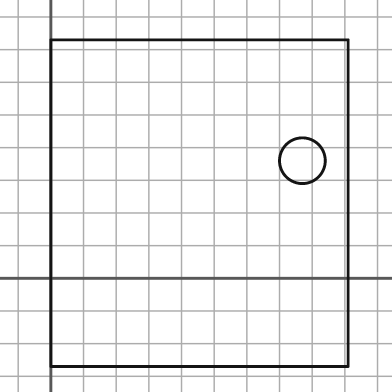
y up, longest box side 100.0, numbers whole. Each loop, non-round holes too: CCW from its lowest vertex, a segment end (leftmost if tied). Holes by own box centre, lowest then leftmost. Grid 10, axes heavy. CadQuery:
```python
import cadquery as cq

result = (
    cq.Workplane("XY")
    .moveTo(0.0, -27.0)
    .lineTo(91.0, -27.0)
    .lineTo(91.0, 73.0)
    .lineTo(0.0, 73.0)
    .close()
    .moveTo(77.0, 36.0)
    .circle(7.0)
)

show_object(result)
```